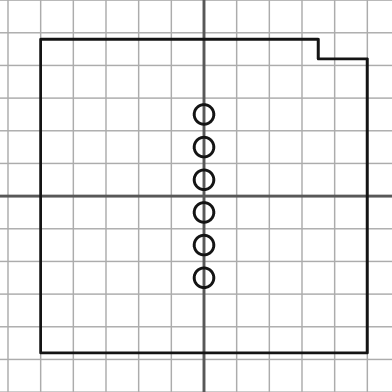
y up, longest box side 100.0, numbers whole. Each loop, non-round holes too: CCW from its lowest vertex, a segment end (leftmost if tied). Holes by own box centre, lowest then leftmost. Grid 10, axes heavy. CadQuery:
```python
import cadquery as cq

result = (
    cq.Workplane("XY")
    .moveTo(-50.0, -48.0)
    .lineTo(50.0, -48.0)
    .lineTo(50.0, 42.0)
    .lineTo(35.0, 42.0)
    .lineTo(35.0, 48.0)
    .lineTo(-50.0, 48.0)
    .close()
    .moveTo(0.0, -25.0)
    .circle(3.0)
    .moveTo(0.0, -15.0)
    .circle(3.0)
    .moveTo(0.0, -5.0)
    .circle(3.0)
    .moveTo(0.0, 5.0)
    .circle(3.0)
    .moveTo(0.0, 15.0)
    .circle(3.0)
    .moveTo(0.0, 25.0)
    .circle(3.0)
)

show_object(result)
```